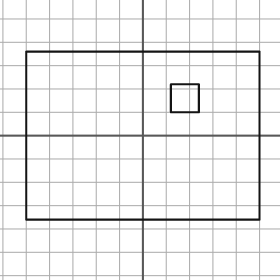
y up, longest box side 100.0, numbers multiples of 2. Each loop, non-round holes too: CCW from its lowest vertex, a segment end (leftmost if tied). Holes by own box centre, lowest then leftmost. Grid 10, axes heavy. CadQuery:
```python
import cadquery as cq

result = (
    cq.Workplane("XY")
    .moveTo(-50.0, -36.0)
    .lineTo(50.0, -36.0)
    .lineTo(50.0, 36.0)
    .lineTo(-50.0, 36.0)
    .close()
    .moveTo(12.0, 10.0)
    .lineTo(24.0, 10.0)
    .lineTo(24.0, 22.0)
    .lineTo(12.0, 22.0)
    .close()
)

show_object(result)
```